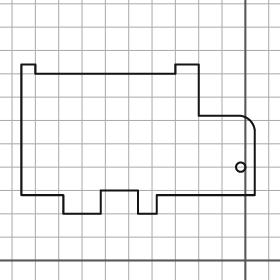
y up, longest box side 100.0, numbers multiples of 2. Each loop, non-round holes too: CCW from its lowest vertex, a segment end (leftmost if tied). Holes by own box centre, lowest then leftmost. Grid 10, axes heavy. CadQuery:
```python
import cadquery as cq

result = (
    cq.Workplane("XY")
    .moveTo(-78.0, 20.0)
    .lineTo(-62.0, 20.0)
    .lineTo(-62.0, 30.0)
    .lineTo(-46.0, 30.0)
    .lineTo(-46.0, 20.0)
    .lineTo(-38.0, 20.0)
    .lineTo(-38.0, 28.0)
    .lineTo(4.0, 28.0)
    .lineTo(4.0, 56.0)
    .threePointArc((2.0, 60.0), (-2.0, 62.0))
    .lineTo(-20.0, 62.0)
    .lineTo(-20.0, 84.0)
    .lineTo(-30.0, 84.0)
    .lineTo(-30.0, 80.0)
    .lineTo(-90.0, 80.0)
    .lineTo(-90.0, 84.0)
    .lineTo(-96.0, 84.0)
    .lineTo(-96.0, 28.0)
    .lineTo(-78.0, 28.0)
    .close()
    .moveTo(-2.0, 40.0)
    .circle(2.0)
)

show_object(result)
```